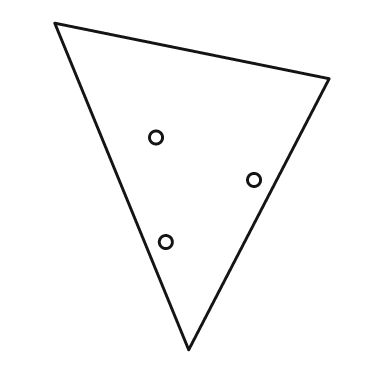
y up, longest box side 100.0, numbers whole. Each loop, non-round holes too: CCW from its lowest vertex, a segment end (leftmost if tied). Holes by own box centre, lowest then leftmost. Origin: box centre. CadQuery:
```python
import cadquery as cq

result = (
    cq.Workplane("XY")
    .moveTo(-1.0, -50.0)
    .lineTo(42.0, 33.0)
    .lineTo(-42.0, 50.0)
    .close()
    .moveTo(-8.0, -17.0)
    .circle(2.0)
    .moveTo(19.0, 2.0)
    .circle(2.0)
    .moveTo(-11.0, 15.0)
    .circle(2.0)
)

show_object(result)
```